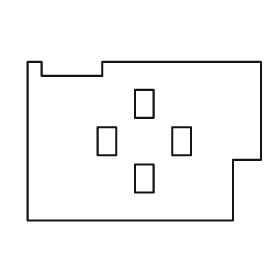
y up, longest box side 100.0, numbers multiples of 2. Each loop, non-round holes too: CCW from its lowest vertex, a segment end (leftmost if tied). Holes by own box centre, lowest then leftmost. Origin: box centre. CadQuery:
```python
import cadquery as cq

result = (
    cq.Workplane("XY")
    .moveTo(-50.0, -34.0)
    .lineTo(38.0, -34.0)
    .lineTo(38.0, -8.0)
    .lineTo(50.0, -8.0)
    .lineTo(50.0, 34.0)
    .lineTo(-18.0, 34.0)
    .lineTo(-18.0, 28.0)
    .lineTo(-44.0, 28.0)
    .lineTo(-44.0, 34.0)
    .lineTo(-50.0, 34.0)
    .close()
    .moveTo(-4.0, -22.0)
    .lineTo(4.0, -22.0)
    .lineTo(4.0, -10.0)
    .lineTo(-4.0, -10.0)
    .close()
    .moveTo(-20.0, -6.0)
    .lineTo(-12.0, -6.0)
    .lineTo(-12.0, 6.0)
    .lineTo(-20.0, 6.0)
    .close()
    .moveTo(12.0, -6.0)
    .lineTo(20.0, -6.0)
    .lineTo(20.0, 6.0)
    .lineTo(12.0, 6.0)
    .close()
    .moveTo(-4.0, 10.0)
    .lineTo(4.0, 10.0)
    .lineTo(4.0, 22.0)
    .lineTo(-4.0, 22.0)
    .close()
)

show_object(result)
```